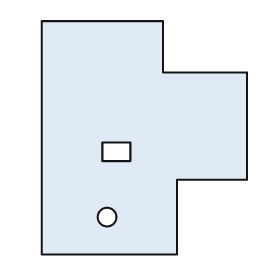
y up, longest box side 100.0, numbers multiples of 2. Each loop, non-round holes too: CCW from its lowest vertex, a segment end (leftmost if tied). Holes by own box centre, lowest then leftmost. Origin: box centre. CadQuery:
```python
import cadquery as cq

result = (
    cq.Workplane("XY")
    .moveTo(-44.0, -50.0)
    .lineTo(14.0, -50.0)
    .lineTo(14.0, -18.0)
    .lineTo(44.0, -18.0)
    .lineTo(44.0, 28.0)
    .lineTo(8.0, 28.0)
    .lineTo(8.0, 50.0)
    .lineTo(-44.0, 50.0)
    .close()
    .moveTo(-16.0, -34.0)
    .circle(4.0)
    .moveTo(-18.0, -10.0)
    .lineTo(-6.0, -10.0)
    .lineTo(-6.0, -2.0)
    .lineTo(-18.0, -2.0)
    .close()
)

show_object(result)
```